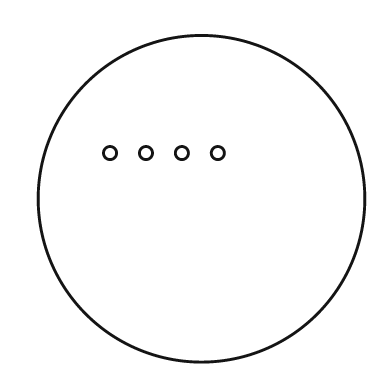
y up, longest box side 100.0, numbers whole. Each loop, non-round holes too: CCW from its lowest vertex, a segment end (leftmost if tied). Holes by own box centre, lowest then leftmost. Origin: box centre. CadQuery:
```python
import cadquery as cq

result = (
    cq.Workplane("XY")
    .moveTo(0.0, 0.0)
    .circle(50.0)
    .moveTo(-28.0, 14.0)
    .circle(2.0)
    .moveTo(-17.0, 14.0)
    .circle(2.0)
    .moveTo(-6.0, 14.0)
    .circle(2.0)
    .moveTo(5.0, 14.0)
    .circle(2.0)
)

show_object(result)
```